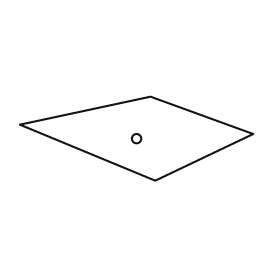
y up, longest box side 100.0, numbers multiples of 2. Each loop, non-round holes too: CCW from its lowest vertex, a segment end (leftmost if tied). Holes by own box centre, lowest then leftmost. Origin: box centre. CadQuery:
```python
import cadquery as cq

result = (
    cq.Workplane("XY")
    .moveTo(8.0, -18.0)
    .lineTo(50.0, 2.0)
    .lineTo(6.0, 18.0)
    .lineTo(-50.0, 6.0)
    .close()
    .moveTo(0.0, 0.0)
    .circle(2.0)
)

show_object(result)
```